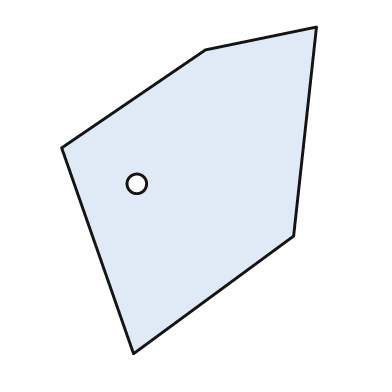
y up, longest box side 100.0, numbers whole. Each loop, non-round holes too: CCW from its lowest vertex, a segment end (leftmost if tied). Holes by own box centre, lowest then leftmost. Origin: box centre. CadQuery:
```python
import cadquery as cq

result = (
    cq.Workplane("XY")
    .moveTo(-17.0, -50.0)
    .lineTo(32.0, -14.0)
    .lineTo(39.0, 50.0)
    .lineTo(5.0, 43.0)
    .lineTo(-39.0, 13.0)
    .close()
    .moveTo(-16.0, 2.0)
    .circle(3.0)
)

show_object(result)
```